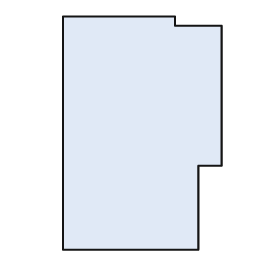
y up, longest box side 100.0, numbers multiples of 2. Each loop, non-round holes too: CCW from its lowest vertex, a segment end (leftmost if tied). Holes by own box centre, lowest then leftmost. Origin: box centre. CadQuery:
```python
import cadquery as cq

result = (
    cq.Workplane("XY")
    .moveTo(-34.0, -50.0)
    .lineTo(24.0, -50.0)
    .lineTo(24.0, -14.0)
    .lineTo(34.0, -14.0)
    .lineTo(34.0, 46.0)
    .lineTo(14.0, 46.0)
    .lineTo(14.0, 50.0)
    .lineTo(-34.0, 50.0)
    .close()
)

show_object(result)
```